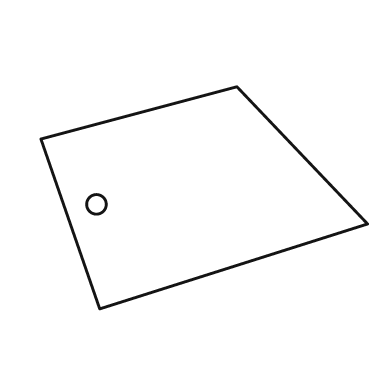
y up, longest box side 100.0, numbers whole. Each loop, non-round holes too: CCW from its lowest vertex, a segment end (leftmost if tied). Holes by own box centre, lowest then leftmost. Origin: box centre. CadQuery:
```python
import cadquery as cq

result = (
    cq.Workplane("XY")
    .moveTo(-32.0, -34.0)
    .lineTo(50.0, -8.0)
    .lineTo(10.0, 34.0)
    .lineTo(-50.0, 18.0)
    .close()
    .moveTo(-33.0, -2.0)
    .circle(3.0)
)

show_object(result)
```